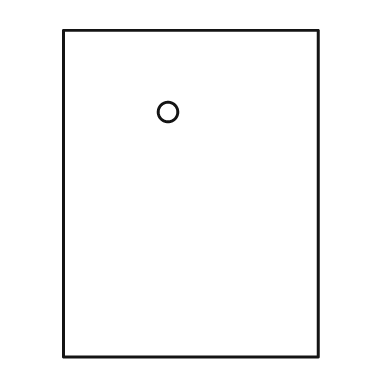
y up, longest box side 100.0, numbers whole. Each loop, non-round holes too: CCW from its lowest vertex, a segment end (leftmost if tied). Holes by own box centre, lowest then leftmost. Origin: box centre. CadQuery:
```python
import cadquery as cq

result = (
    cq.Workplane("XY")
    .moveTo(-39.0, -50.0)
    .lineTo(39.0, -50.0)
    .lineTo(39.0, 50.0)
    .lineTo(-39.0, 50.0)
    .close()
    .moveTo(-7.0, 25.0)
    .circle(3.0)
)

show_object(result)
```